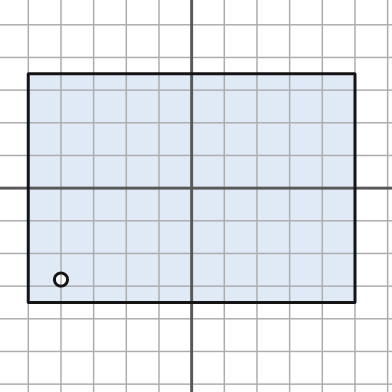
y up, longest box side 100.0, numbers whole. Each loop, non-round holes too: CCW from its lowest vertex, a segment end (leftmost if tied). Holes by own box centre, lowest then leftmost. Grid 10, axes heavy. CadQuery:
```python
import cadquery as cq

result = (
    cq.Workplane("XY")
    .moveTo(-50.0, -35.0)
    .lineTo(50.0, -35.0)
    .lineTo(50.0, 35.0)
    .lineTo(-50.0, 35.0)
    .close()
    .moveTo(-40.0, -28.0)
    .circle(2.0)
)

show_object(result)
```